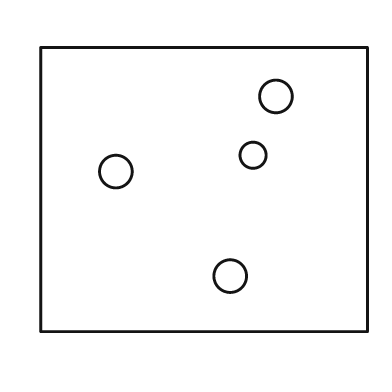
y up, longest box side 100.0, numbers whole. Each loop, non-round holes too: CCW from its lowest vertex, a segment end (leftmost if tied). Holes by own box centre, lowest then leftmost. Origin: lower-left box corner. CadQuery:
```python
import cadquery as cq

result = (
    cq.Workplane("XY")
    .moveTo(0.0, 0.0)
    .lineTo(100.0, 0.0)
    .lineTo(100.0, 87.0)
    .lineTo(0.0, 87.0)
    .close()
    .moveTo(58.0, 17.0)
    .circle(5.0)
    .moveTo(23.0, 49.0)
    .circle(5.0)
    .moveTo(65.0, 54.0)
    .circle(4.0)
    .moveTo(72.0, 72.0)
    .circle(5.0)
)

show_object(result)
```